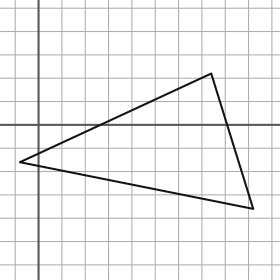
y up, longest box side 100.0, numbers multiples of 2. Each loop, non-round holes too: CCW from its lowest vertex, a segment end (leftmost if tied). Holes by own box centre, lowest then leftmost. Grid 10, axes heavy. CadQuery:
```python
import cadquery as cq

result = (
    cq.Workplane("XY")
    .moveTo(92.0, -36.0)
    .lineTo(74.0, 22.0)
    .lineTo(-8.0, -16.0)
    .close()
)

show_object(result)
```